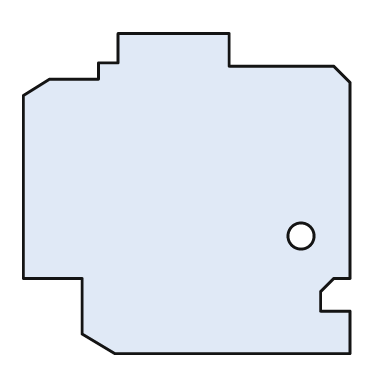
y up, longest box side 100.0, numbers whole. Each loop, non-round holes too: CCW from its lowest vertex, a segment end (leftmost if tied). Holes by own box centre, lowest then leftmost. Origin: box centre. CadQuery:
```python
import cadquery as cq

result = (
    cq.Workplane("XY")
    .moveTo(-22.0, -49.0)
    .lineTo(50.0, -49.0)
    .lineTo(50.0, -36.0)
    .lineTo(41.0, -36.0)
    .lineTo(41.0, -30.0)
    .lineTo(45.0, -26.0)
    .lineTo(50.0, -26.0)
    .lineTo(50.0, 34.0)
    .lineTo(45.0, 39.0)
    .lineTo(13.0, 39.0)
    .lineTo(13.0, 49.0)
    .lineTo(-21.0, 49.0)
    .lineTo(-21.0, 40.0)
    .lineTo(-27.0, 40.0)
    .lineTo(-27.0, 35.0)
    .lineTo(-42.0, 35.0)
    .lineTo(-50.0, 30.0)
    .lineTo(-50.0, -26.0)
    .lineTo(-32.0, -26.0)
    .lineTo(-32.0, -43.0)
    .close()
    .moveTo(35.0, -13.0)
    .circle(4.0)
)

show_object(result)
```